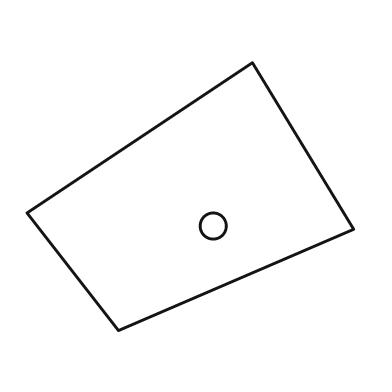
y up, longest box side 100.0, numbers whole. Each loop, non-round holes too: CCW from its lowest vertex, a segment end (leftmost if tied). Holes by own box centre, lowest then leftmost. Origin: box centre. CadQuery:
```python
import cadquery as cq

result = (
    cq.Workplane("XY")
    .moveTo(-22.0, -41.0)
    .lineTo(50.0, -10.0)
    .lineTo(19.0, 41.0)
    .lineTo(-50.0, -5.0)
    .close()
    .moveTo(7.0, -9.0)
    .circle(4.0)
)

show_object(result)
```